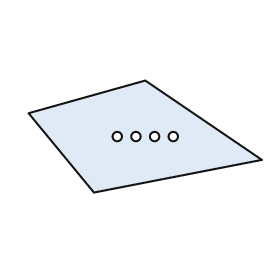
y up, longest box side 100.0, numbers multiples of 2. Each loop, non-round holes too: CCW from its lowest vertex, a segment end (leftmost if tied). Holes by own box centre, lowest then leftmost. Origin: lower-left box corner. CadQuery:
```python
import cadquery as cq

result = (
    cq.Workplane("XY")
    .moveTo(28.0, 0.0)
    .lineTo(100.0, 14.0)
    .lineTo(50.0, 48.0)
    .lineTo(0.0, 34.0)
    .close()
    .moveTo(38.0, 24.0)
    .circle(2.0)
    .moveTo(46.0, 24.0)
    .circle(2.0)
    .moveTo(54.0, 24.0)
    .circle(2.0)
    .moveTo(62.0, 24.0)
    .circle(2.0)
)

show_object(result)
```